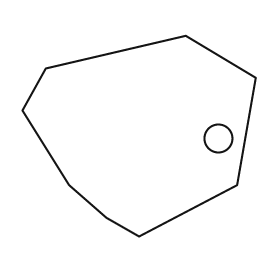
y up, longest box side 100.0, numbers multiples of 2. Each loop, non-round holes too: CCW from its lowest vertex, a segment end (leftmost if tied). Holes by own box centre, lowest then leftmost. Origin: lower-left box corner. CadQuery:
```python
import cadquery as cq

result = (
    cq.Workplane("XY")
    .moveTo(50.0, 0.0)
    .lineTo(92.0, 22.0)
    .lineTo(100.0, 68.0)
    .lineTo(70.0, 86.0)
    .lineTo(10.0, 72.0)
    .lineTo(0.0, 54.0)
    .lineTo(20.0, 22.0)
    .lineTo(36.0, 8.0)
    .close()
    .moveTo(84.0, 42.0)
    .circle(6.0)
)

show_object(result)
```